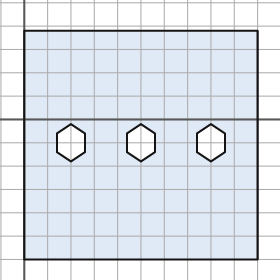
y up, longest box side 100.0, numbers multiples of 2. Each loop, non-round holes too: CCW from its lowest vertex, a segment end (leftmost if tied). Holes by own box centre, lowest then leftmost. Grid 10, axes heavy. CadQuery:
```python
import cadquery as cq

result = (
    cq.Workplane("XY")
    .moveTo(0.0, -60.0)
    .lineTo(100.0, -60.0)
    .lineTo(100.0, 38.0)
    .lineTo(0.0, 38.0)
    .close()
    .moveTo(20.0, -18.0)
    .lineTo(26.0, -14.0)
    .lineTo(26.0, -6.0)
    .lineTo(20.0, -2.0)
    .lineTo(14.0, -6.0)
    .lineTo(14.0, -14.0)
    .close()
    .moveTo(50.0, -18.0)
    .lineTo(56.0, -14.0)
    .lineTo(56.0, -6.0)
    .lineTo(50.0, -2.0)
    .lineTo(44.0, -6.0)
    .lineTo(44.0, -14.0)
    .close()
    .moveTo(80.0, -18.0)
    .lineTo(86.0, -14.0)
    .lineTo(86.0, -6.0)
    .lineTo(80.0, -2.0)
    .lineTo(74.0, -6.0)
    .lineTo(74.0, -14.0)
    .close()
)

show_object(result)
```